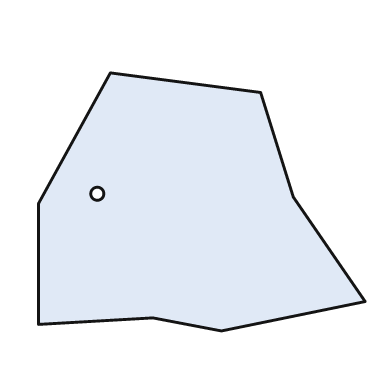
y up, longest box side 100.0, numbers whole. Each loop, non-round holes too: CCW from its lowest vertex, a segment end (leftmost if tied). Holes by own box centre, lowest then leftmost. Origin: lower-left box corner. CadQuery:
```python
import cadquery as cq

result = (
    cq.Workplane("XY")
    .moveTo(56.0, 0.0)
    .lineTo(100.0, 9.0)
    .lineTo(78.0, 41.0)
    .lineTo(68.0, 73.0)
    .lineTo(22.0, 79.0)
    .lineTo(0.0, 39.0)
    .lineTo(0.0, 2.0)
    .lineTo(35.0, 4.0)
    .close()
    .moveTo(18.0, 42.0)
    .circle(2.0)
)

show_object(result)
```